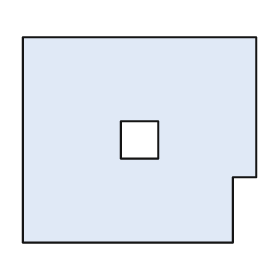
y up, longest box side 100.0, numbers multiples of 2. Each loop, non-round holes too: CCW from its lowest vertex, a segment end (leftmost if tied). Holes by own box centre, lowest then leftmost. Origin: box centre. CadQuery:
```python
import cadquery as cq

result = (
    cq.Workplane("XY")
    .moveTo(-50.0, -44.0)
    .lineTo(40.0, -44.0)
    .lineTo(40.0, -16.0)
    .lineTo(50.0, -16.0)
    .lineTo(50.0, 44.0)
    .lineTo(-50.0, 44.0)
    .close()
    .moveTo(-8.0, -8.0)
    .lineTo(8.0, -8.0)
    .lineTo(8.0, 8.0)
    .lineTo(-8.0, 8.0)
    .close()
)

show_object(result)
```